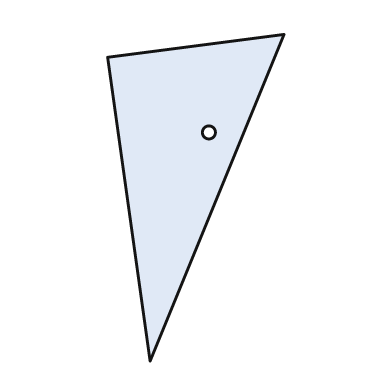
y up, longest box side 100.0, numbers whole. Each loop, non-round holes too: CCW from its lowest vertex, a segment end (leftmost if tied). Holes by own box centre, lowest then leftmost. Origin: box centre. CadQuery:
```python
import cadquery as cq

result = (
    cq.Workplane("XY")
    .moveTo(-14.0, -50.0)
    .lineTo(27.0, 50.0)
    .lineTo(-27.0, 43.0)
    .close()
    .moveTo(4.0, 20.0)
    .circle(2.0)
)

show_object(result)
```